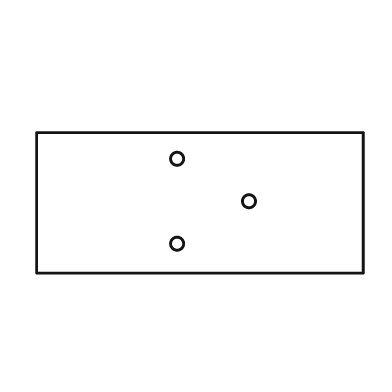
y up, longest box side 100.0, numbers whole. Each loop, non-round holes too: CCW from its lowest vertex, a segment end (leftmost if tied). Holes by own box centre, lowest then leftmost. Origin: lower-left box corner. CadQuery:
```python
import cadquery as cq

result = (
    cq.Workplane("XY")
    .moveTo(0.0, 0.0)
    .lineTo(100.0, 0.0)
    .lineTo(100.0, 43.0)
    .lineTo(0.0, 43.0)
    .close()
    .moveTo(43.0, 9.0)
    .circle(2.0)
    .moveTo(65.0, 22.0)
    .circle(2.0)
    .moveTo(43.0, 35.0)
    .circle(2.0)
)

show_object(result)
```